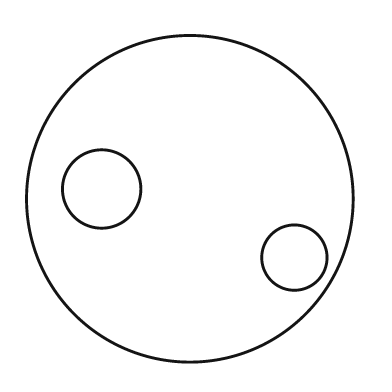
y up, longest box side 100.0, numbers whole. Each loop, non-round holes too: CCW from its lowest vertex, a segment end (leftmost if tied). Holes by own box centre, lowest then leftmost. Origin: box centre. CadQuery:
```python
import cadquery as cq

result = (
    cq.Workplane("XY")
    .moveTo(0.0, 0.0)
    .circle(50.0)
    .moveTo(32.0, -18.0)
    .circle(10.0)
    .moveTo(-27.0, 3.0)
    .circle(12.0)
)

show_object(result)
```